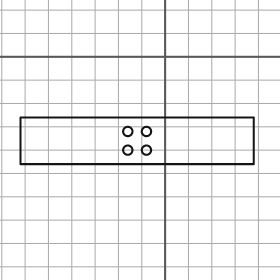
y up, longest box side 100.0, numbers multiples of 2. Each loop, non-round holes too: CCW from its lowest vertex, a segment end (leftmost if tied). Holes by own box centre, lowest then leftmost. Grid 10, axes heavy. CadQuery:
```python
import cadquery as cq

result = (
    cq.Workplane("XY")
    .moveTo(-62.0, -46.0)
    .lineTo(38.0, -46.0)
    .lineTo(38.0, -26.0)
    .lineTo(-62.0, -26.0)
    .close()
    .moveTo(-16.0, -40.0)
    .circle(2.0)
    .moveTo(-8.0, -40.0)
    .circle(2.0)
    .moveTo(-16.0, -32.0)
    .circle(2.0)
    .moveTo(-8.0, -32.0)
    .circle(2.0)
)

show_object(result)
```